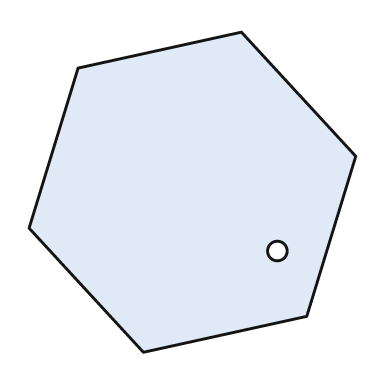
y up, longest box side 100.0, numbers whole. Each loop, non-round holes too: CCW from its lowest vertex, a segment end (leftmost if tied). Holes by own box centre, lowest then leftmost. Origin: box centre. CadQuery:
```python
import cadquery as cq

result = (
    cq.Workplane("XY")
    .moveTo(-15.0, -49.0)
    .lineTo(35.0, -38.0)
    .lineTo(50.0, 11.0)
    .lineTo(15.0, 49.0)
    .lineTo(-35.0, 38.0)
    .lineTo(-50.0, -11.0)
    .close()
    .moveTo(26.0, -18.0)
    .circle(3.0)
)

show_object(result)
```